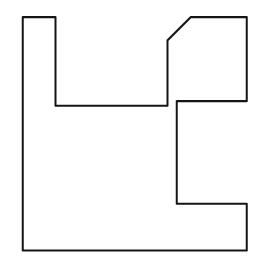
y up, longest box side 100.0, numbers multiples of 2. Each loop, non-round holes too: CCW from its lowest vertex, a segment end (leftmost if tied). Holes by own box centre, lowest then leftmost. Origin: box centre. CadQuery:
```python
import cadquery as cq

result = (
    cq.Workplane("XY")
    .moveTo(-48.0, -50.0)
    .lineTo(48.0, -50.0)
    .lineTo(48.0, -30.0)
    .lineTo(18.0, -30.0)
    .lineTo(18.0, 14.0)
    .lineTo(48.0, 14.0)
    .lineTo(48.0, 50.0)
    .lineTo(24.0, 50.0)
    .lineTo(14.0, 40.0)
    .lineTo(14.0, 12.0)
    .lineTo(-34.0, 12.0)
    .lineTo(-34.0, 50.0)
    .lineTo(-48.0, 50.0)
    .close()
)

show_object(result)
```